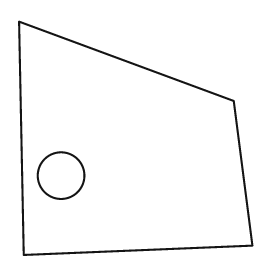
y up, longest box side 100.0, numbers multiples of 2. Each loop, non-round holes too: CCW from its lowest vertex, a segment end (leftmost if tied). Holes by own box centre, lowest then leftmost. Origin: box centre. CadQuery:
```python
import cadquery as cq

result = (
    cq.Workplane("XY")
    .moveTo(-48.0, -50.0)
    .lineTo(50.0, -46.0)
    .lineTo(42.0, 16.0)
    .lineTo(-50.0, 50.0)
    .close()
    .moveTo(-32.0, -16.0)
    .circle(10.0)
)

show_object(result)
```